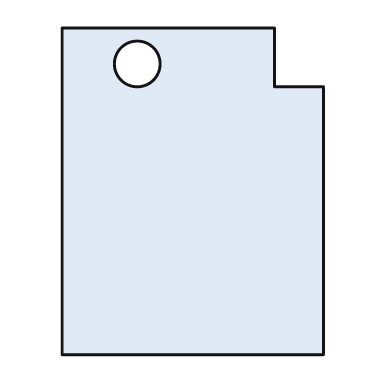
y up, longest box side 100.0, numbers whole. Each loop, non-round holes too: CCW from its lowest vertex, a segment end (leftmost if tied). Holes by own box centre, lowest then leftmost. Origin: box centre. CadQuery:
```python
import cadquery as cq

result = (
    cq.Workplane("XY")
    .moveTo(-40.0, -50.0)
    .lineTo(40.0, -50.0)
    .lineTo(40.0, 32.0)
    .lineTo(25.0, 32.0)
    .lineTo(25.0, 50.0)
    .lineTo(-40.0, 50.0)
    .close()
    .moveTo(-17.0, 39.0)
    .circle(7.0)
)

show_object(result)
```